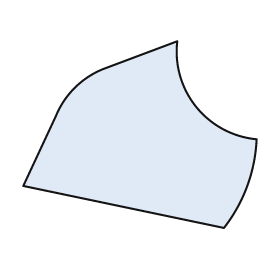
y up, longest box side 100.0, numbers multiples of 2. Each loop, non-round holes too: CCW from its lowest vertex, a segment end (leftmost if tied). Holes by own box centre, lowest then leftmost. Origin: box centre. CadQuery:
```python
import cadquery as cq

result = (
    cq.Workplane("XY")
    .moveTo(36.0, -40.0)
    .threePointArc((46.0, -22.0), (50.0, -2.0))
    .threePointArc((24.0, 12.0), (16.0, 40.0))
    .lineTo(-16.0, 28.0)
    .threePointArc((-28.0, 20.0), (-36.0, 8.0))
    .lineTo(-50.0, -22.0)
    .close()
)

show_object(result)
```